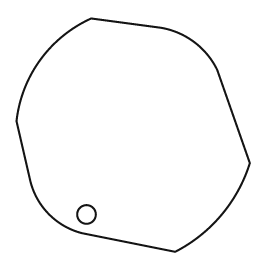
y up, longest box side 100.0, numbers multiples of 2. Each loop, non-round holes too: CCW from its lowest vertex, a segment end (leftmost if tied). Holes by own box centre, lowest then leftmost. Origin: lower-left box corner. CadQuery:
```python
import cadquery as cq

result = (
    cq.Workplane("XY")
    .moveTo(68.0, 0.0)
    .threePointArc((88.0, 16.0), (100.0, 38.0))
    .lineTo(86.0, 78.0)
    .threePointArc((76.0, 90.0), (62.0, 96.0))
    .lineTo(32.0, 100.0)
    .threePointArc((10.0, 82.0), (0.0, 56.0))
    .lineTo(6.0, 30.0)
    .threePointArc((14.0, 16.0), (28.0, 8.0))
    .close()
    .moveTo(30.0, 16.0)
    .circle(4.0)
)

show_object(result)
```